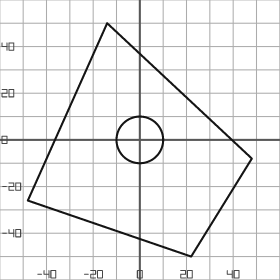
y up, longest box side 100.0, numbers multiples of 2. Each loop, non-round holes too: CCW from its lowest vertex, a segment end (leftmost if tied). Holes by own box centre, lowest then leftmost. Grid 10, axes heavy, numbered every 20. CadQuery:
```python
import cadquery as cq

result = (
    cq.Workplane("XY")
    .moveTo(22.0, -50.0)
    .lineTo(48.0, -8.0)
    .lineTo(-14.0, 50.0)
    .lineTo(-48.0, -26.0)
    .close()
    .moveTo(0.0, 0.0)
    .circle(10.0)
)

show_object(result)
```